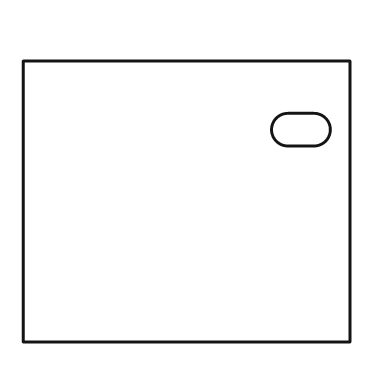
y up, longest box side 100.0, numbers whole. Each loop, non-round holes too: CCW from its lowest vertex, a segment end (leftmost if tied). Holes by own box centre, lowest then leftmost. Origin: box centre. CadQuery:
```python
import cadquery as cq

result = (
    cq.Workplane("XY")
    .moveTo(-50.0, -43.0)
    .lineTo(50.0, -43.0)
    .lineTo(50.0, 43.0)
    .lineTo(-50.0, 43.0)
    .close()
    .moveTo(31.0, 17.0)
    .lineTo(39.0, 17.0)
    .threePointArc((44.0, 22.0), (39.0, 27.0))
    .lineTo(31.0, 27.0)
    .threePointArc((26.0, 22.0), (31.0, 17.0))
    .close()
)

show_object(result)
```